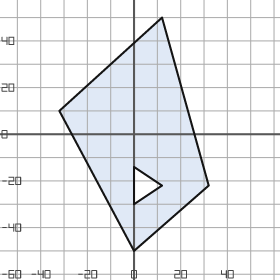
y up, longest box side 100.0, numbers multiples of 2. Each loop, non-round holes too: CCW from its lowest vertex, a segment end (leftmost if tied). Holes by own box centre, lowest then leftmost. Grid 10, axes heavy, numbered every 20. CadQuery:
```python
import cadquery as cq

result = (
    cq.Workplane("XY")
    .moveTo(0.0, -50.0)
    .lineTo(32.0, -22.0)
    .lineTo(12.0, 50.0)
    .lineTo(-32.0, 10.0)
    .close()
    .moveTo(0.0, -30.0)
    .lineTo(12.0, -22.0)
    .lineTo(0.0, -14.0)
    .close()
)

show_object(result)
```